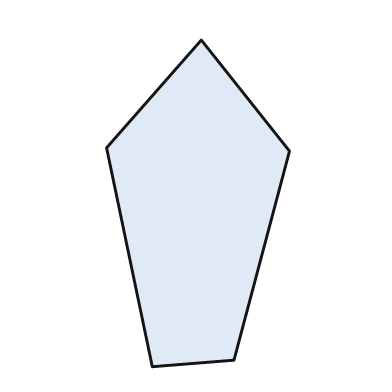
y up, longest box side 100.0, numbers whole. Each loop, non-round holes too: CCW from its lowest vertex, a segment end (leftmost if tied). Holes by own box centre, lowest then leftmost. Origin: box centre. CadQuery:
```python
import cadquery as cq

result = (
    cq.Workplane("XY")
    .moveTo(-14.0, -50.0)
    .lineTo(11.0, -48.0)
    .lineTo(28.0, 16.0)
    .lineTo(1.0, 50.0)
    .lineTo(-28.0, 17.0)
    .close()
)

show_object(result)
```